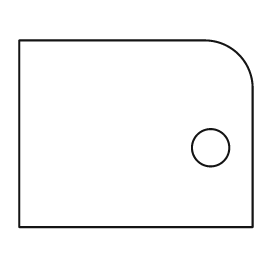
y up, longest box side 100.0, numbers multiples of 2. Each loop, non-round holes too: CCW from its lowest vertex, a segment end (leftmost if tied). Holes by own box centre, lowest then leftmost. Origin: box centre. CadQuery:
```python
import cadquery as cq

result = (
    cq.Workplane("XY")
    .moveTo(-50.0, -40.0)
    .lineTo(50.0, -40.0)
    .lineTo(50.0, 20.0)
    .threePointArc((44.0, 34.0), (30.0, 40.0))
    .lineTo(-50.0, 40.0)
    .close()
    .moveTo(32.0, -6.0)
    .circle(8.0)
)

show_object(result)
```